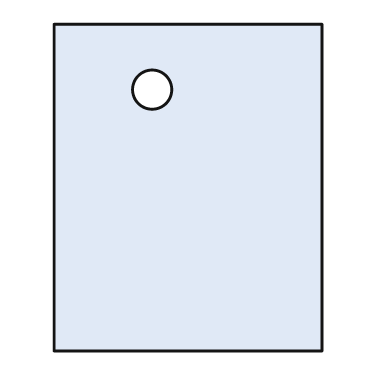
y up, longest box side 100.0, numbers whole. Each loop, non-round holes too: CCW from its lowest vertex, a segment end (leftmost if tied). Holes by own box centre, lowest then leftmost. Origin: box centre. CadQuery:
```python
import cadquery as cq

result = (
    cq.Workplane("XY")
    .moveTo(-41.0, -50.0)
    .lineTo(41.0, -50.0)
    .lineTo(41.0, 50.0)
    .lineTo(-41.0, 50.0)
    .close()
    .moveTo(-11.0, 30.0)
    .circle(6.0)
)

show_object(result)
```